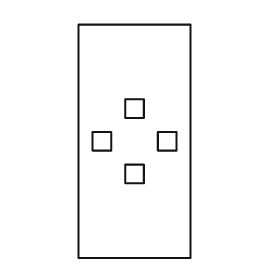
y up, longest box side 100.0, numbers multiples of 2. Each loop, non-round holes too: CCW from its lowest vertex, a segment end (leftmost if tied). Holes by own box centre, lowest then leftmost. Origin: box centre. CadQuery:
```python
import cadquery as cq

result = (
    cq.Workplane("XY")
    .moveTo(-24.0, -50.0)
    .lineTo(24.0, -50.0)
    .lineTo(24.0, 50.0)
    .lineTo(-24.0, 50.0)
    .close()
    .moveTo(-4.0, -18.0)
    .lineTo(4.0, -18.0)
    .lineTo(4.0, -10.0)
    .lineTo(-4.0, -10.0)
    .close()
    .moveTo(-18.0, -4.0)
    .lineTo(-10.0, -4.0)
    .lineTo(-10.0, 4.0)
    .lineTo(-18.0, 4.0)
    .close()
    .moveTo(10.0, -4.0)
    .lineTo(18.0, -4.0)
    .lineTo(18.0, 4.0)
    .lineTo(10.0, 4.0)
    .close()
    .moveTo(-4.0, 10.0)
    .lineTo(4.0, 10.0)
    .lineTo(4.0, 18.0)
    .lineTo(-4.0, 18.0)
    .close()
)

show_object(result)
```